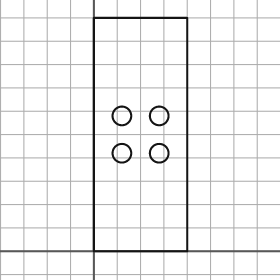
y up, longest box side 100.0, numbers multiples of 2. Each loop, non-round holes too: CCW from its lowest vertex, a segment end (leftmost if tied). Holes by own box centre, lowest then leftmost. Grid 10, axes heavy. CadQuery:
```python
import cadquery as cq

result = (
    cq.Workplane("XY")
    .moveTo(0.0, 0.0)
    .lineTo(40.0, 0.0)
    .lineTo(40.0, 100.0)
    .lineTo(0.0, 100.0)
    .close()
    .moveTo(12.0, 42.0)
    .circle(4.0)
    .moveTo(28.0, 42.0)
    .circle(4.0)
    .moveTo(12.0, 58.0)
    .circle(4.0)
    .moveTo(28.0, 58.0)
    .circle(4.0)
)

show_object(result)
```